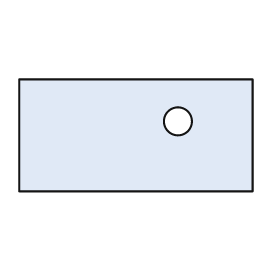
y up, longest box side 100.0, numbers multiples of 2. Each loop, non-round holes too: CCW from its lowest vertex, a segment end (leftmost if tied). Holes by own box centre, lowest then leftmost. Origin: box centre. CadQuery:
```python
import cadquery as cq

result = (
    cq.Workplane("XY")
    .moveTo(-50.0, -24.0)
    .lineTo(50.0, -24.0)
    .lineTo(50.0, 24.0)
    .lineTo(-50.0, 24.0)
    .close()
    .moveTo(18.0, 6.0)
    .circle(6.0)
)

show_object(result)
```